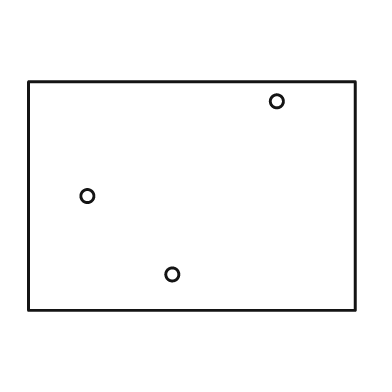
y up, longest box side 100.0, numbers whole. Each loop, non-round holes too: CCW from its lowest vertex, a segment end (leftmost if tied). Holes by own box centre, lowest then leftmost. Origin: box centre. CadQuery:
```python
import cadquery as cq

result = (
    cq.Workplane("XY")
    .moveTo(-50.0, -35.0)
    .lineTo(50.0, -35.0)
    .lineTo(50.0, 35.0)
    .lineTo(-50.0, 35.0)
    .close()
    .moveTo(-6.0, -24.0)
    .circle(2.0)
    .moveTo(-32.0, 0.0)
    .circle(2.0)
    .moveTo(26.0, 29.0)
    .circle(2.0)
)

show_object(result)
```